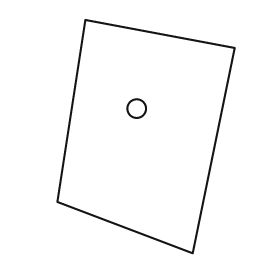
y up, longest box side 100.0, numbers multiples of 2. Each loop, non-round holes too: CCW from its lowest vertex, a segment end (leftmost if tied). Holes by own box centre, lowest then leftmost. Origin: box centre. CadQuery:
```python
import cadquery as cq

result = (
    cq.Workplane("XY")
    .moveTo(20.0, -50.0)
    .lineTo(38.0, 38.0)
    .lineTo(-26.0, 50.0)
    .lineTo(-38.0, -28.0)
    .close()
    .moveTo(-4.0, 12.0)
    .circle(4.0)
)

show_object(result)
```